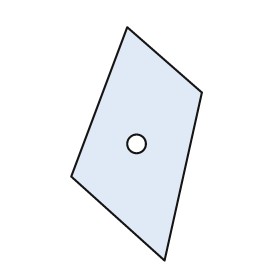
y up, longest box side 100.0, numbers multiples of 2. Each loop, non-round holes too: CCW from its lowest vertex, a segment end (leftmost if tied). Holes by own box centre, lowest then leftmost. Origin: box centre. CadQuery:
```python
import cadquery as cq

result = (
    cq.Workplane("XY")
    .moveTo(12.0, -50.0)
    .lineTo(28.0, 22.0)
    .lineTo(-4.0, 50.0)
    .lineTo(-28.0, -14.0)
    .close()
    .moveTo(0.0, 0.0)
    .circle(4.0)
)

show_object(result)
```